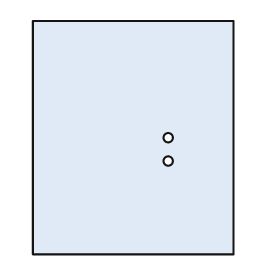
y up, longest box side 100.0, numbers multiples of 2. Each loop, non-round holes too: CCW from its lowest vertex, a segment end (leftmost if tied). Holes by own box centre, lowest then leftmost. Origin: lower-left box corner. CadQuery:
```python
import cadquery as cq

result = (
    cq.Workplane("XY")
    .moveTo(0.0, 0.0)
    .lineTo(86.0, 0.0)
    .lineTo(86.0, 100.0)
    .lineTo(0.0, 100.0)
    .close()
    .moveTo(58.0, 40.0)
    .circle(2.0)
    .moveTo(58.0, 50.0)
    .circle(2.0)
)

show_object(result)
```